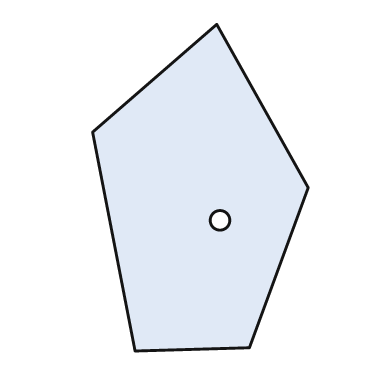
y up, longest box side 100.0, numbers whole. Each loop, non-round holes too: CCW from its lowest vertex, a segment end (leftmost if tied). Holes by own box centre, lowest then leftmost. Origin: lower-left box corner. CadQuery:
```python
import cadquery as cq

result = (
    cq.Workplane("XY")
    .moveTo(13.0, 0.0)
    .lineTo(48.0, 1.0)
    .lineTo(66.0, 50.0)
    .lineTo(38.0, 100.0)
    .lineTo(0.0, 67.0)
    .close()
    .moveTo(39.0, 40.0)
    .circle(3.0)
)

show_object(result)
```